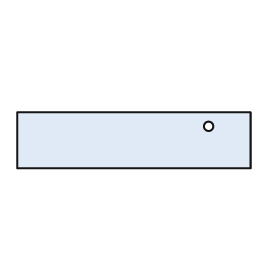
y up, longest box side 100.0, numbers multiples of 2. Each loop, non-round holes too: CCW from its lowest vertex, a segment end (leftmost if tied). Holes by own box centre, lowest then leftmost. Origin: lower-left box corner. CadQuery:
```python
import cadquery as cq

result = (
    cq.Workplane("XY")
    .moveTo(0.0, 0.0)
    .lineTo(100.0, 0.0)
    .lineTo(100.0, 24.0)
    .lineTo(0.0, 24.0)
    .close()
    .moveTo(82.0, 18.0)
    .circle(2.0)
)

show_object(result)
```